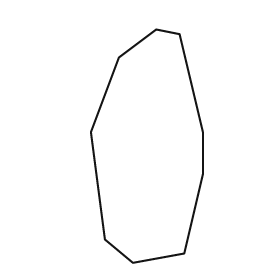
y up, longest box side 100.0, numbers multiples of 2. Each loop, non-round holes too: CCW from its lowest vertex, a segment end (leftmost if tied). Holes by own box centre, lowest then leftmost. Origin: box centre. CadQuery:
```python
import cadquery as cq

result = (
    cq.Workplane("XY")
    .moveTo(-6.0, -50.0)
    .lineTo(16.0, -46.0)
    .lineTo(24.0, -12.0)
    .lineTo(24.0, 6.0)
    .lineTo(14.0, 48.0)
    .lineTo(4.0, 50.0)
    .lineTo(-12.0, 38.0)
    .lineTo(-24.0, 6.0)
    .lineTo(-18.0, -40.0)
    .close()
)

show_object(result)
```